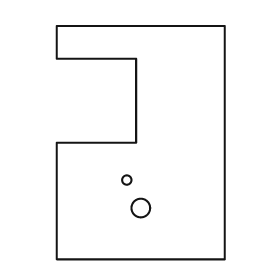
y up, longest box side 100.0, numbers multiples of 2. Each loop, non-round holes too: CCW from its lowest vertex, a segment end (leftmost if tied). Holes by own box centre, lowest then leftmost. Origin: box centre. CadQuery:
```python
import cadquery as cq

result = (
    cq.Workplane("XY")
    .moveTo(-36.0, -50.0)
    .lineTo(36.0, -50.0)
    .lineTo(36.0, 50.0)
    .lineTo(-36.0, 50.0)
    .lineTo(-36.0, 36.0)
    .lineTo(-2.0, 36.0)
    .lineTo(-2.0, 0.0)
    .lineTo(-36.0, 0.0)
    .close()
    .moveTo(0.0, -28.0)
    .circle(4.0)
    .moveTo(-6.0, -16.0)
    .circle(2.0)
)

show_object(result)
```